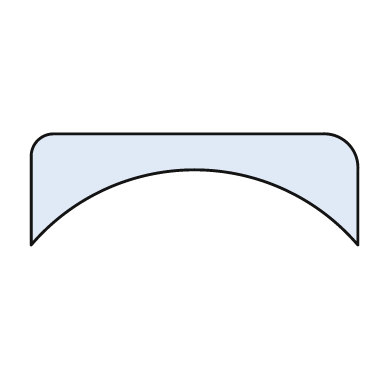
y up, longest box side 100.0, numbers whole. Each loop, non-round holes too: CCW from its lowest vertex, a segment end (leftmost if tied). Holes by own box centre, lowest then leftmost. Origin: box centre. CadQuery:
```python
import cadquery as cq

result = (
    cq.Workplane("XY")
    .moveTo(-50.0, -17.0)
    .threePointArc((0.0, 6.0), (50.0, -17.0))
    .lineTo(50.0, 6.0)
    .threePointArc((47.0, 14.0), (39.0, 17.0))
    .lineTo(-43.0, 17.0)
    .threePointArc((-48.0, 15.0), (-50.0, 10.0))
    .close()
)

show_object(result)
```